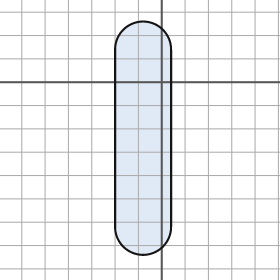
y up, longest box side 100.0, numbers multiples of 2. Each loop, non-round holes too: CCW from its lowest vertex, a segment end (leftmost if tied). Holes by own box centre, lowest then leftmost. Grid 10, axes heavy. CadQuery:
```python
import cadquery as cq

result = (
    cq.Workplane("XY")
    .moveTo(-20.0, -62.0)
    .threePointArc((-8.0, -74.0), (4.0, -62.0))
    .lineTo(4.0, 14.0)
    .threePointArc((-8.0, 26.0), (-20.0, 14.0))
    .close()
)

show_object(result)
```